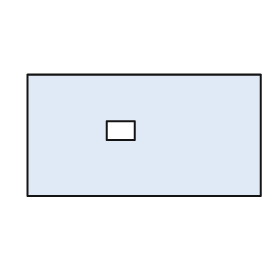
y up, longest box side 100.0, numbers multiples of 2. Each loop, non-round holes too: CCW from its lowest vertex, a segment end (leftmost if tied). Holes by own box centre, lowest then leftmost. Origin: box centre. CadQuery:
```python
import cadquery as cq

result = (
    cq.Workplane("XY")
    .moveTo(-50.0, -26.0)
    .lineTo(50.0, -26.0)
    .lineTo(50.0, 26.0)
    .lineTo(-50.0, 26.0)
    .close()
    .moveTo(-16.0, -2.0)
    .lineTo(-4.0, -2.0)
    .lineTo(-4.0, 6.0)
    .lineTo(-16.0, 6.0)
    .close()
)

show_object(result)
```